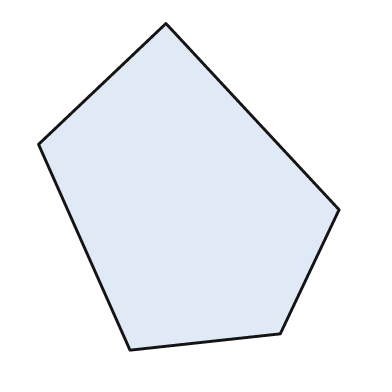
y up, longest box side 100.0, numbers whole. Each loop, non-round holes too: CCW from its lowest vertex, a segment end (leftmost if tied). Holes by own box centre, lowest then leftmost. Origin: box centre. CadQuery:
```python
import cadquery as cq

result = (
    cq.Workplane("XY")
    .moveTo(-18.0, -50.0)
    .lineTo(28.0, -45.0)
    .lineTo(46.0, -7.0)
    .lineTo(-7.0, 50.0)
    .lineTo(-46.0, 13.0)
    .close()
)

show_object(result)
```